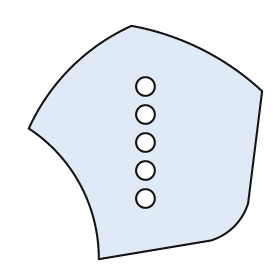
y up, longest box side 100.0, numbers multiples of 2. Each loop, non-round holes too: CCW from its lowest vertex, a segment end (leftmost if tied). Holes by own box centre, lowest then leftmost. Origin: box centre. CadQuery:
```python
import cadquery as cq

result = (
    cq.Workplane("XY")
    .moveTo(-20.0, -50.0)
    .lineTo(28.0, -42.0)
    .threePointArc((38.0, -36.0), (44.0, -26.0))
    .lineTo(50.0, 22.0)
    .threePointArc((24.0, 40.0), (-6.0, 50.0))
    .threePointArc((-32.0, 32.0), (-50.0, 6.0))
    .threePointArc((-28.0, -18.0), (-20.0, -50.0))
    .close()
    .moveTo(0.0, -24.0)
    .circle(4.0)
    .moveTo(0.0, -12.0)
    .circle(4.0)
    .moveTo(0.0, 0.0)
    .circle(4.0)
    .moveTo(0.0, 12.0)
    .circle(4.0)
    .moveTo(0.0, 24.0)
    .circle(4.0)
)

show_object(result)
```